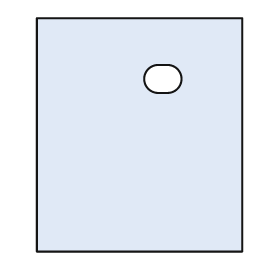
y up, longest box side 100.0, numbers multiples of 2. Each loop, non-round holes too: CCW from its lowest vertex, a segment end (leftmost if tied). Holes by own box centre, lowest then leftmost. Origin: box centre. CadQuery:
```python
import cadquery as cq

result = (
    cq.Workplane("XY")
    .moveTo(-44.0, -50.0)
    .lineTo(44.0, -50.0)
    .lineTo(44.0, 50.0)
    .lineTo(-44.0, 50.0)
    .close()
    .moveTo(8.0, 18.0)
    .lineTo(12.0, 18.0)
    .threePointArc((18.0, 24.0), (12.0, 30.0))
    .lineTo(8.0, 30.0)
    .threePointArc((2.0, 24.0), (8.0, 18.0))
    .close()
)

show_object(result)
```